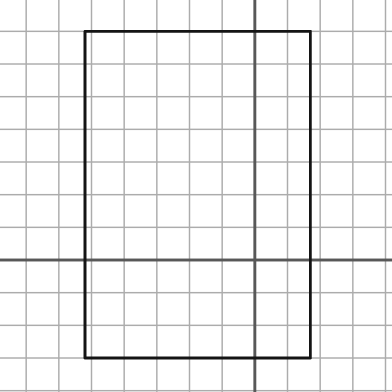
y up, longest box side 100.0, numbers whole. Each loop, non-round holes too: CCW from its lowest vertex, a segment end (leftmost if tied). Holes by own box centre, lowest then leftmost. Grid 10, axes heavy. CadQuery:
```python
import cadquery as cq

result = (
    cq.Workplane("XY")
    .moveTo(-52.0, -30.0)
    .lineTo(17.0, -30.0)
    .lineTo(17.0, 70.0)
    .lineTo(-52.0, 70.0)
    .close()
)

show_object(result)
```